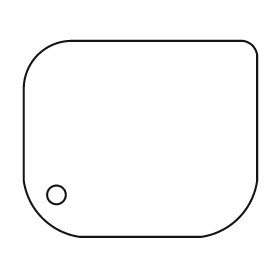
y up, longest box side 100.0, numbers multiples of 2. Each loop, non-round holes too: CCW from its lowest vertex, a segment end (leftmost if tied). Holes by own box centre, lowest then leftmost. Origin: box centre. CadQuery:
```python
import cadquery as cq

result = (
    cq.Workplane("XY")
    .moveTo(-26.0, -42.0)
    .lineTo(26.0, -42.0)
    .threePointArc((42.0, -34.0), (50.0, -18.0))
    .lineTo(50.0, 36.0)
    .threePointArc((48.0, 40.0), (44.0, 42.0))
    .lineTo(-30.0, 42.0)
    .threePointArc((-44.0, 36.0), (-50.0, 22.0))
    .lineTo(-50.0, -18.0)
    .threePointArc((-42.0, -34.0), (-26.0, -42.0))
    .close()
    .moveTo(-36.0, -24.0)
    .circle(4.0)
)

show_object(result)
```